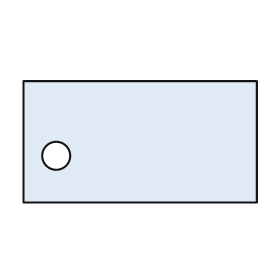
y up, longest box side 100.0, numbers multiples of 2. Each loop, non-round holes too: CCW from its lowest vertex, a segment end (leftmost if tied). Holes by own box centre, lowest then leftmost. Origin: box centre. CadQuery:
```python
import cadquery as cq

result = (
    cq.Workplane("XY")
    .moveTo(-50.0, -26.0)
    .lineTo(50.0, -26.0)
    .lineTo(50.0, 26.0)
    .lineTo(-50.0, 26.0)
    .close()
    .moveTo(-36.0, -6.0)
    .circle(6.0)
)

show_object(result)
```